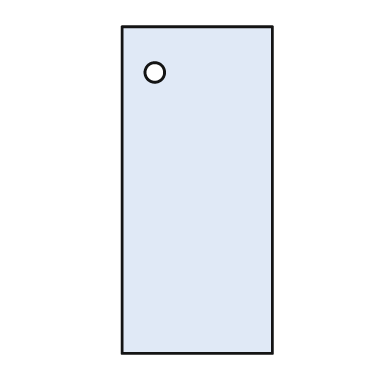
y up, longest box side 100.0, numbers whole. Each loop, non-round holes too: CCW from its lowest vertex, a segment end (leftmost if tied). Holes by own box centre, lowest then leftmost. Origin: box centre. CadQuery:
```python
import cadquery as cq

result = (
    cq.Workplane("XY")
    .moveTo(-23.0, -50.0)
    .lineTo(23.0, -50.0)
    .lineTo(23.0, 50.0)
    .lineTo(-23.0, 50.0)
    .close()
    .moveTo(-13.0, 36.0)
    .circle(3.0)
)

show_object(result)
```